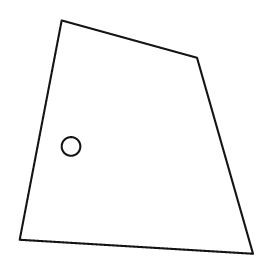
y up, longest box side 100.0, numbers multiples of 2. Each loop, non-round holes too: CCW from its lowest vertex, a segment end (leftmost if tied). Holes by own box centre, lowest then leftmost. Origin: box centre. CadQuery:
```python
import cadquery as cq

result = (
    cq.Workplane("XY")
    .moveTo(50.0, -50.0)
    .lineTo(26.0, 34.0)
    .lineTo(-32.0, 50.0)
    .lineTo(-50.0, -44.0)
    .close()
    .moveTo(-28.0, -4.0)
    .circle(4.0)
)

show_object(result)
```